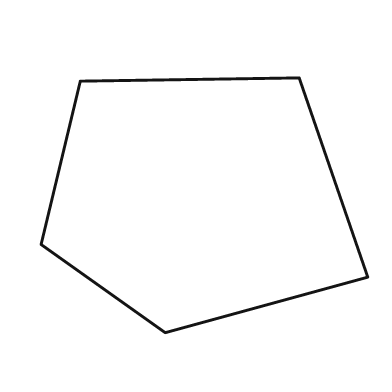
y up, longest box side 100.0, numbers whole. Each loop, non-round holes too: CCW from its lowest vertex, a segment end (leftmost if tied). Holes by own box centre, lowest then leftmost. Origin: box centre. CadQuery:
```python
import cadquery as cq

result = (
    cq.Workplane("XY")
    .moveTo(-12.0, -39.0)
    .lineTo(50.0, -22.0)
    .lineTo(29.0, 39.0)
    .lineTo(-38.0, 38.0)
    .lineTo(-50.0, -12.0)
    .close()
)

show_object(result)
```